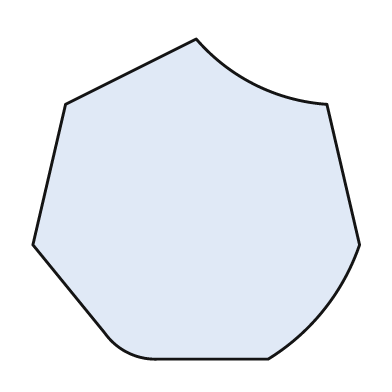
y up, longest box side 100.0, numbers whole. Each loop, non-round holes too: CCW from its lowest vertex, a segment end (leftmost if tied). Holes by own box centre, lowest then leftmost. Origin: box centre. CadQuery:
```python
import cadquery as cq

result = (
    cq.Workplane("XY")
    .moveTo(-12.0, -49.0)
    .lineTo(22.0, -49.0)
    .threePointArc((39.0, -34.0), (50.0, -14.0))
    .lineTo(40.0, 29.0)
    .threePointArc((18.0, 35.0), (0.0, 49.0))
    .lineTo(-40.0, 29.0)
    .lineTo(-50.0, -14.0)
    .lineTo(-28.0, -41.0)
    .threePointArc((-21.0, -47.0), (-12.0, -49.0))
    .close()
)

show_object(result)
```